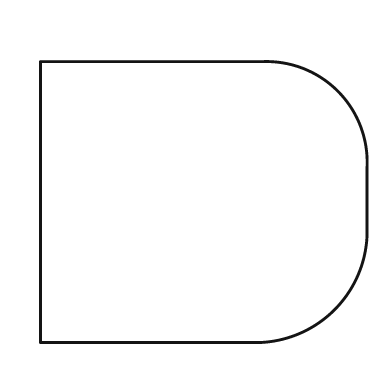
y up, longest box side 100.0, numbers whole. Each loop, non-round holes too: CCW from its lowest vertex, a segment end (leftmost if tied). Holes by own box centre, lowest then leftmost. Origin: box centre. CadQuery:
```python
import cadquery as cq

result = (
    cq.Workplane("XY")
    .moveTo(-50.0, -43.0)
    .lineTo(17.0, -43.0)
    .threePointArc((40.0, -33.0), (50.0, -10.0))
    .lineTo(50.0, 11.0)
    .threePointArc((41.0, 34.0), (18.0, 43.0))
    .lineTo(-50.0, 43.0)
    .close()
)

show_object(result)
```